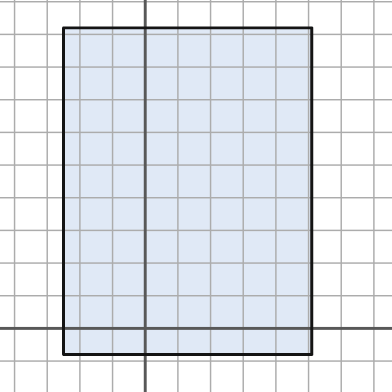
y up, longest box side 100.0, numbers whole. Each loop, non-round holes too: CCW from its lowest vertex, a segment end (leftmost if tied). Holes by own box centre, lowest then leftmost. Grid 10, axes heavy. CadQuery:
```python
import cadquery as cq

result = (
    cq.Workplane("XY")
    .moveTo(-25.0, -8.0)
    .lineTo(51.0, -8.0)
    .lineTo(51.0, 92.0)
    .lineTo(-25.0, 92.0)
    .close()
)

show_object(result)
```